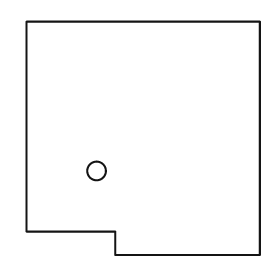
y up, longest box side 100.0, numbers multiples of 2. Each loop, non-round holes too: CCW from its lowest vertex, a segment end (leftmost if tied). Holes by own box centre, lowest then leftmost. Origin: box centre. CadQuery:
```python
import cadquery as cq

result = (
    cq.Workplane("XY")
    .moveTo(-12.0, -50.0)
    .lineTo(50.0, -50.0)
    .lineTo(50.0, 50.0)
    .lineTo(-50.0, 50.0)
    .lineTo(-50.0, -40.0)
    .lineTo(-12.0, -40.0)
    .close()
    .moveTo(-20.0, -14.0)
    .circle(4.0)
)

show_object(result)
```